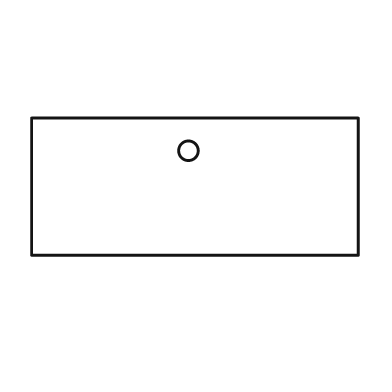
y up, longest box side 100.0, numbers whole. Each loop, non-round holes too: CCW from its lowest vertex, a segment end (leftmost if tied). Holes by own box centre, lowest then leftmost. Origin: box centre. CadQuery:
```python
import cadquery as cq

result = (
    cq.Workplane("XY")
    .moveTo(-50.0, -21.0)
    .lineTo(50.0, -21.0)
    .lineTo(50.0, 21.0)
    .lineTo(-50.0, 21.0)
    .close()
    .moveTo(-2.0, 11.0)
    .circle(3.0)
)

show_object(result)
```